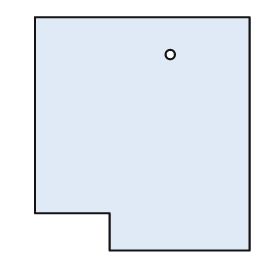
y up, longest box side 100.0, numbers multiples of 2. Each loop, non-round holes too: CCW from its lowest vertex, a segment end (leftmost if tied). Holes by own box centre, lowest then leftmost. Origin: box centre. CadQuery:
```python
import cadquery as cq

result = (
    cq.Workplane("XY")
    .moveTo(-14.0, -50.0)
    .lineTo(46.0, -50.0)
    .lineTo(46.0, 50.0)
    .lineTo(-46.0, 50.0)
    .lineTo(-46.0, -34.0)
    .lineTo(-14.0, -34.0)
    .close()
    .moveTo(12.0, 34.0)
    .circle(2.0)
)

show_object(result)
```